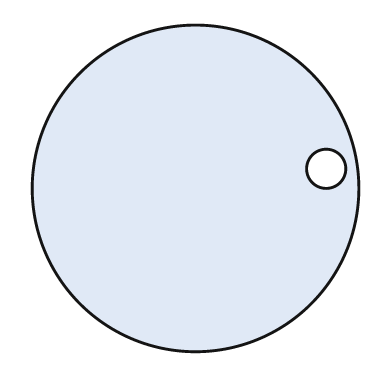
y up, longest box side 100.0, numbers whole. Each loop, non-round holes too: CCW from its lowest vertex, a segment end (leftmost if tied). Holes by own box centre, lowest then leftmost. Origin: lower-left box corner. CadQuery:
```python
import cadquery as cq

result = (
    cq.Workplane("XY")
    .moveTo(50.0, 50.0)
    .circle(50.0)
    .moveTo(90.0, 56.0)
    .circle(6.0)
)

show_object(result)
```